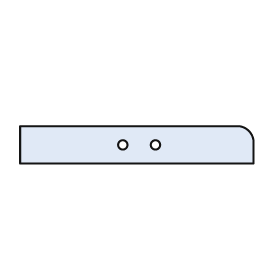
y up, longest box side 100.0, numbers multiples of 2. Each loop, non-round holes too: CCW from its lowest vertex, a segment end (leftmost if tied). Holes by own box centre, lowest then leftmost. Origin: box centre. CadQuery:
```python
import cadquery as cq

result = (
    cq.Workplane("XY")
    .moveTo(-50.0, -8.0)
    .lineTo(50.0, -8.0)
    .lineTo(50.0, 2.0)
    .threePointArc((48.0, 6.0), (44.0, 8.0))
    .lineTo(-50.0, 8.0)
    .close()
    .moveTo(-6.0, 0.0)
    .circle(2.0)
    .moveTo(8.0, 0.0)
    .circle(2.0)
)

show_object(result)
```